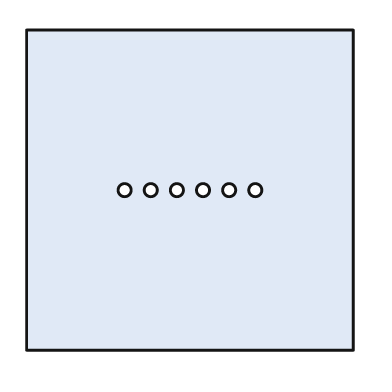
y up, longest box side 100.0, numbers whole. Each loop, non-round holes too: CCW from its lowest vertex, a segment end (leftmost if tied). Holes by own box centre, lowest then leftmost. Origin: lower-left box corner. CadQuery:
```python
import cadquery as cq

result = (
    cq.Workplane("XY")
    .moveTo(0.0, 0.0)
    .lineTo(100.0, 0.0)
    .lineTo(100.0, 98.0)
    .lineTo(0.0, 98.0)
    .close()
    .moveTo(30.0, 49.0)
    .circle(2.0)
    .moveTo(38.0, 49.0)
    .circle(2.0)
    .moveTo(46.0, 49.0)
    .circle(2.0)
    .moveTo(54.0, 49.0)
    .circle(2.0)
    .moveTo(62.0, 49.0)
    .circle(2.0)
    .moveTo(70.0, 49.0)
    .circle(2.0)
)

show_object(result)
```